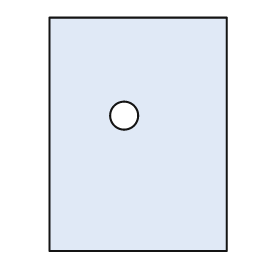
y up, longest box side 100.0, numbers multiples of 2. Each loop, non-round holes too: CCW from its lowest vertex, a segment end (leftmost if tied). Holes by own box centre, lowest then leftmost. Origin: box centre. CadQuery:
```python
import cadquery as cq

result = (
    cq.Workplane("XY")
    .moveTo(-38.0, -50.0)
    .lineTo(38.0, -50.0)
    .lineTo(38.0, 50.0)
    .lineTo(-38.0, 50.0)
    .close()
    .moveTo(-6.0, 8.0)
    .circle(6.0)
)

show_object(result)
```